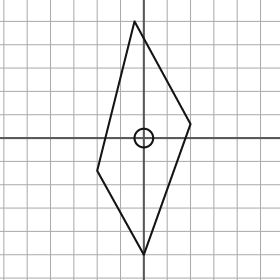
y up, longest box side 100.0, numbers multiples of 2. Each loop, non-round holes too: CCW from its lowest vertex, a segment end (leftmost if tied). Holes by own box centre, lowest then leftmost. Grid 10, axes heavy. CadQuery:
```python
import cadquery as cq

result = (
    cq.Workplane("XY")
    .moveTo(0.0, -50.0)
    .lineTo(20.0, 6.0)
    .lineTo(-4.0, 50.0)
    .lineTo(-20.0, -14.0)
    .close()
    .moveTo(0.0, 0.0)
    .circle(4.0)
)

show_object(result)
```